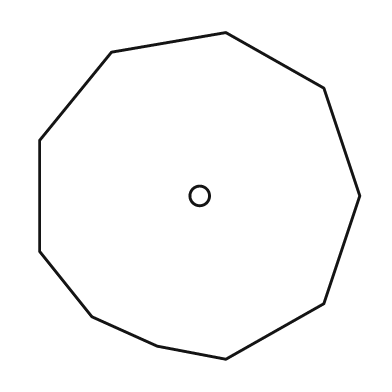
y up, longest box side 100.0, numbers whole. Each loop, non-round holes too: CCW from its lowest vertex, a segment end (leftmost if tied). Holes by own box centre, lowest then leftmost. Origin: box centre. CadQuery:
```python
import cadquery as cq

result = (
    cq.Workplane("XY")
    .moveTo(8.0, -50.0)
    .lineTo(38.0, -33.0)
    .lineTo(49.0, 0.0)
    .lineTo(38.0, 33.0)
    .lineTo(8.0, 50.0)
    .lineTo(-27.0, 44.0)
    .lineTo(-49.0, 17.0)
    .lineTo(-49.0, -17.0)
    .lineTo(-33.0, -37.0)
    .lineTo(-13.0, -46.0)
    .close()
    .moveTo(0.0, 0.0)
    .circle(3.0)
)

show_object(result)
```